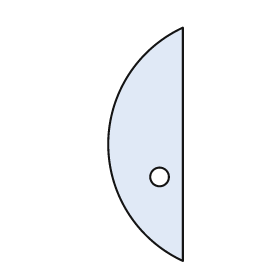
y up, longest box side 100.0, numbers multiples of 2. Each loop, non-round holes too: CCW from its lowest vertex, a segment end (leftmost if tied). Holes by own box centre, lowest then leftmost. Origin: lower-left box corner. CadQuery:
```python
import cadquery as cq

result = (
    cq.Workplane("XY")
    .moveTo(32.0, 0.0)
    .lineTo(32.0, 100.0)
    .threePointArc((0.0, 50.0), (32.0, 0.0))
    .close()
    .moveTo(22.0, 36.0)
    .circle(4.0)
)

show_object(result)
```